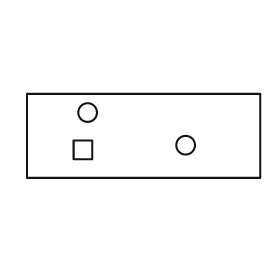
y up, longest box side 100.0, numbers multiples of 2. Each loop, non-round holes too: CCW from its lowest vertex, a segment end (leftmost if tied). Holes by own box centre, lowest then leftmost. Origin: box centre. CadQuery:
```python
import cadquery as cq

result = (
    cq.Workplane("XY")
    .moveTo(-50.0, -18.0)
    .lineTo(50.0, -18.0)
    .lineTo(50.0, 18.0)
    .lineTo(-50.0, 18.0)
    .close()
    .moveTo(-30.0, -10.0)
    .lineTo(-22.0, -10.0)
    .lineTo(-22.0, -2.0)
    .lineTo(-30.0, -2.0)
    .close()
    .moveTo(18.0, -4.0)
    .circle(4.0)
    .moveTo(-24.0, 10.0)
    .circle(4.0)
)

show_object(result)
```